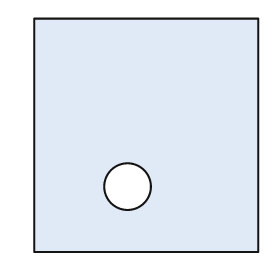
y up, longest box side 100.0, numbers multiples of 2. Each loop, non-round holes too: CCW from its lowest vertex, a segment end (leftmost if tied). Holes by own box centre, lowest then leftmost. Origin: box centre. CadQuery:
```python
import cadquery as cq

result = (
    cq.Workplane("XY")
    .moveTo(-48.0, -50.0)
    .lineTo(48.0, -50.0)
    .lineTo(48.0, 50.0)
    .lineTo(-48.0, 50.0)
    .close()
    .moveTo(-8.0, -22.0)
    .circle(10.0)
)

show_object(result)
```